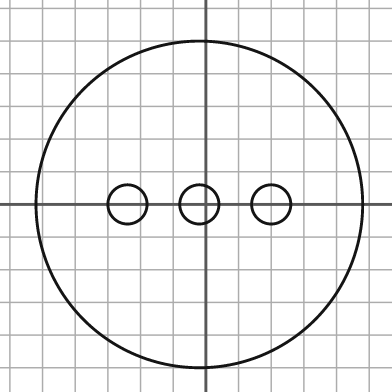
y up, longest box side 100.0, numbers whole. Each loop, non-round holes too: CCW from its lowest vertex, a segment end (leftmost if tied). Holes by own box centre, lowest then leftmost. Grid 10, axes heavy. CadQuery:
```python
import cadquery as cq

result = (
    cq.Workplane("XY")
    .moveTo(-2.0, 0.0)
    .circle(50.0)
    .moveTo(-24.0, 0.0)
    .circle(6.0)
    .moveTo(-2.0, 0.0)
    .circle(6.0)
    .moveTo(20.0, 0.0)
    .circle(6.0)
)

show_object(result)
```